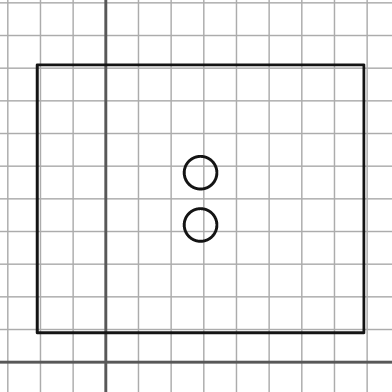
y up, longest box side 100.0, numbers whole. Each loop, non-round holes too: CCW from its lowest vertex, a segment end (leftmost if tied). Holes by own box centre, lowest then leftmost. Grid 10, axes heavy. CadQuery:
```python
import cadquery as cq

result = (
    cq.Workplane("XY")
    .moveTo(-21.0, 9.0)
    .lineTo(79.0, 9.0)
    .lineTo(79.0, 91.0)
    .lineTo(-21.0, 91.0)
    .close()
    .moveTo(29.0, 42.0)
    .circle(5.0)
    .moveTo(29.0, 58.0)
    .circle(5.0)
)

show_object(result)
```